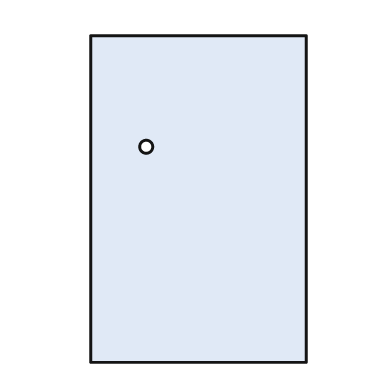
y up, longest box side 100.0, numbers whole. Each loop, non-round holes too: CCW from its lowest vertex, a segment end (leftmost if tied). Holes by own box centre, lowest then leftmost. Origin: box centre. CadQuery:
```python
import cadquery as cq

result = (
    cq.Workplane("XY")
    .moveTo(-33.0, -50.0)
    .lineTo(33.0, -50.0)
    .lineTo(33.0, 50.0)
    .lineTo(-33.0, 50.0)
    .close()
    .moveTo(-16.0, 16.0)
    .circle(2.0)
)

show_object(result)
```